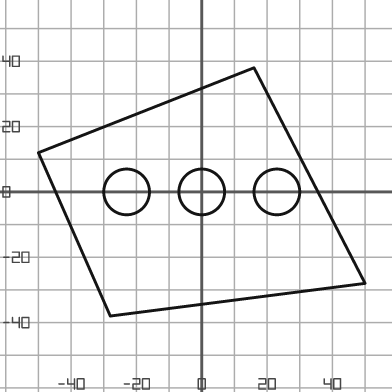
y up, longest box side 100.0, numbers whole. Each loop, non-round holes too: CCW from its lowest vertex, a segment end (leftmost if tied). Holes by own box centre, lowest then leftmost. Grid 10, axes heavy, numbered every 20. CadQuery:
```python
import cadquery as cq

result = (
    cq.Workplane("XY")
    .moveTo(-28.0, -38.0)
    .lineTo(50.0, -28.0)
    .lineTo(16.0, 38.0)
    .lineTo(-50.0, 12.0)
    .close()
    .moveTo(-23.0, 0.0)
    .circle(7.0)
    .moveTo(0.0, 0.0)
    .circle(7.0)
    .moveTo(23.0, 0.0)
    .circle(7.0)
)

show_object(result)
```